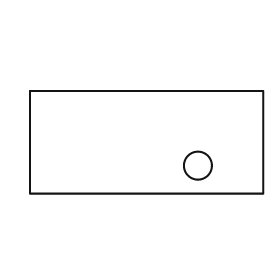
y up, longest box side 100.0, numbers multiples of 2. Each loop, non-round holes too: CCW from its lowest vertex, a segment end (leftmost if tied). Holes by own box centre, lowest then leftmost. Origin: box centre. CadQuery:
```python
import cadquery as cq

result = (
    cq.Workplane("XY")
    .moveTo(-50.0, -22.0)
    .lineTo(50.0, -22.0)
    .lineTo(50.0, 22.0)
    .lineTo(-50.0, 22.0)
    .close()
    .moveTo(22.0, -10.0)
    .circle(6.0)
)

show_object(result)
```